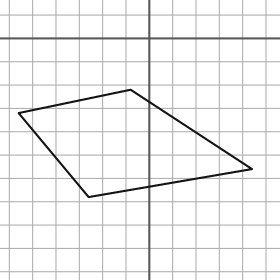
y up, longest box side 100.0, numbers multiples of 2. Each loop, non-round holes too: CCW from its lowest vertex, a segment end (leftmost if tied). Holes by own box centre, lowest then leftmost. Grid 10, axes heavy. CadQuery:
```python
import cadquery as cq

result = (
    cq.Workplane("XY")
    .moveTo(-26.0, -68.0)
    .lineTo(44.0, -56.0)
    .lineTo(-8.0, -22.0)
    .lineTo(-56.0, -32.0)
    .close()
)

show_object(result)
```